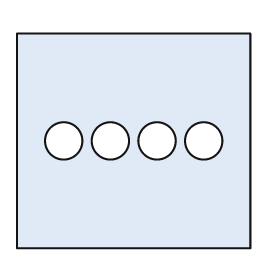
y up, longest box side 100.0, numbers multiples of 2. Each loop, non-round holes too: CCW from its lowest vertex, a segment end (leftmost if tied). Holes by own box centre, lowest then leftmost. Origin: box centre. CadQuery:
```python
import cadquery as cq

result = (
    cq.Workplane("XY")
    .moveTo(-50.0, -46.0)
    .lineTo(50.0, -46.0)
    .lineTo(50.0, 46.0)
    .lineTo(-50.0, 46.0)
    .close()
    .moveTo(-30.0, 0.0)
    .circle(8.0)
    .moveTo(-10.0, 0.0)
    .circle(8.0)
    .moveTo(10.0, 0.0)
    .circle(8.0)
    .moveTo(30.0, 0.0)
    .circle(8.0)
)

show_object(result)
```